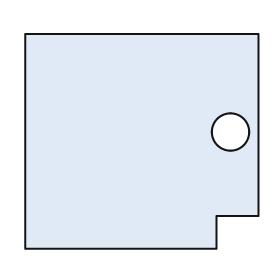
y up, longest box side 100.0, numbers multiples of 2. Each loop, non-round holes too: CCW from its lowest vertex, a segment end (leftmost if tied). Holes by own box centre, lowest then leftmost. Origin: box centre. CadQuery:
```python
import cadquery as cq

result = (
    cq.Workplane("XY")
    .moveTo(-50.0, -46.0)
    .lineTo(32.0, -46.0)
    .lineTo(32.0, -32.0)
    .lineTo(50.0, -32.0)
    .lineTo(50.0, 46.0)
    .lineTo(-50.0, 46.0)
    .close()
    .moveTo(38.0, 4.0)
    .circle(8.0)
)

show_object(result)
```